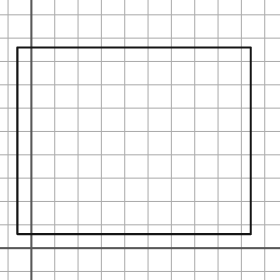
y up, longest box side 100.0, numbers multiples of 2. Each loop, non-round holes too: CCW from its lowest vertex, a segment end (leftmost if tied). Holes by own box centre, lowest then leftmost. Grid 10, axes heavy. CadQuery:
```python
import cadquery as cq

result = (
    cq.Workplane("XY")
    .moveTo(-6.0, 6.0)
    .lineTo(94.0, 6.0)
    .lineTo(94.0, 86.0)
    .lineTo(-6.0, 86.0)
    .close()
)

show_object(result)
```